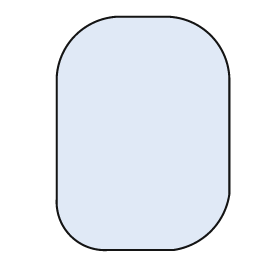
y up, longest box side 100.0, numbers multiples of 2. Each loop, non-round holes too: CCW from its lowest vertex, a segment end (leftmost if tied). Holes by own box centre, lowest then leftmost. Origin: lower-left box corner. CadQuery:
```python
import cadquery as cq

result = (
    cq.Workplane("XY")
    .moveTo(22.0, 0.0)
    .lineTo(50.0, 0.0)
    .threePointArc((66.0, 8.0), (74.0, 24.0))
    .lineTo(74.0, 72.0)
    .threePointArc((66.0, 92.0), (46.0, 100.0))
    .lineTo(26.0, 100.0)
    .threePointArc((8.0, 92.0), (0.0, 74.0))
    .lineTo(0.0, 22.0)
    .threePointArc((6.0, 6.0), (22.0, 0.0))
    .close()
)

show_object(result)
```